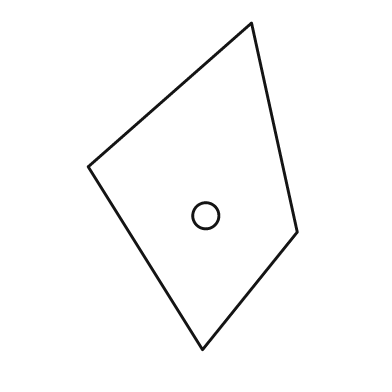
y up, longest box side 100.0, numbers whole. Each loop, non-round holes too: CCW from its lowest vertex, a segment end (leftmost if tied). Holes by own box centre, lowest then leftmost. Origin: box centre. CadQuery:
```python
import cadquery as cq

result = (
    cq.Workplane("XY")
    .moveTo(3.0, -50.0)
    .lineTo(32.0, -14.0)
    .lineTo(18.0, 50.0)
    .lineTo(-32.0, 6.0)
    .close()
    .moveTo(4.0, -9.0)
    .circle(4.0)
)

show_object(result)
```